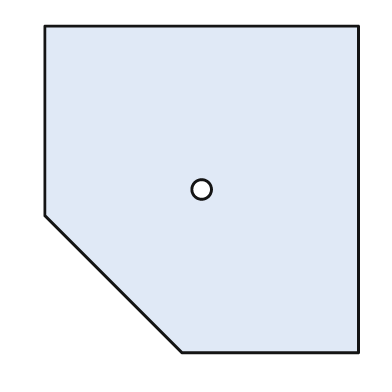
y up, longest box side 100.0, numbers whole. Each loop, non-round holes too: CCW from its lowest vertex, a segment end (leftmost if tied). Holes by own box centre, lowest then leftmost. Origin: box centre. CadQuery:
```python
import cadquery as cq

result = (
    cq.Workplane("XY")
    .moveTo(-6.0, -50.0)
    .lineTo(48.0, -50.0)
    .lineTo(48.0, 50.0)
    .lineTo(-48.0, 50.0)
    .lineTo(-48.0, -8.0)
    .close()
    .moveTo(0.0, 0.0)
    .circle(3.0)
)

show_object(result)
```